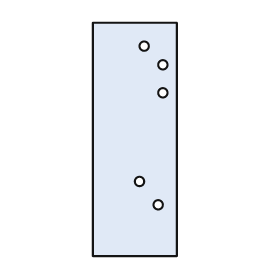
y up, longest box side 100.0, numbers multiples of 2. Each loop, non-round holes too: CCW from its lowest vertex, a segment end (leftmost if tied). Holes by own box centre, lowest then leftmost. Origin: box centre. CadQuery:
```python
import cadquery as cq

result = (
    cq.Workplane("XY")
    .moveTo(-18.0, -50.0)
    .lineTo(18.0, -50.0)
    .lineTo(18.0, 50.0)
    .lineTo(-18.0, 50.0)
    .close()
    .moveTo(10.0, -28.0)
    .circle(2.0)
    .moveTo(2.0, -18.0)
    .circle(2.0)
    .moveTo(12.0, 20.0)
    .circle(2.0)
    .moveTo(12.0, 32.0)
    .circle(2.0)
    .moveTo(4.0, 40.0)
    .circle(2.0)
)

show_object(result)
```